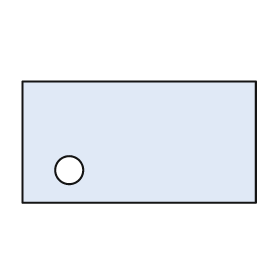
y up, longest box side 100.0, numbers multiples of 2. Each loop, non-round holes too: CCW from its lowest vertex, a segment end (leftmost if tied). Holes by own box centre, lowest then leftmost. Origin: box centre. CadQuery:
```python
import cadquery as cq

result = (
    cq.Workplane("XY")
    .moveTo(-50.0, -26.0)
    .lineTo(50.0, -26.0)
    .lineTo(50.0, 26.0)
    .lineTo(-50.0, 26.0)
    .close()
    .moveTo(-30.0, -12.0)
    .circle(6.0)
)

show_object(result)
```